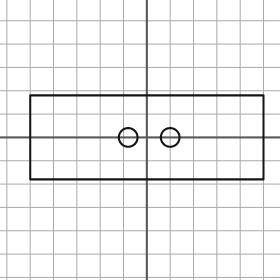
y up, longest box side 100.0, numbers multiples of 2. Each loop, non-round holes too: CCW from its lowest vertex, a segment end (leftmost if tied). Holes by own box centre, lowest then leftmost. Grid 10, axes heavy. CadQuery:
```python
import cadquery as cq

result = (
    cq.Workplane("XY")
    .moveTo(-50.0, -18.0)
    .lineTo(50.0, -18.0)
    .lineTo(50.0, 18.0)
    .lineTo(-50.0, 18.0)
    .close()
    .moveTo(-8.0, 0.0)
    .circle(4.0)
    .moveTo(10.0, 0.0)
    .circle(4.0)
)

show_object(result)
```